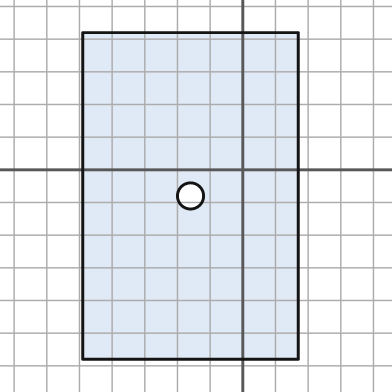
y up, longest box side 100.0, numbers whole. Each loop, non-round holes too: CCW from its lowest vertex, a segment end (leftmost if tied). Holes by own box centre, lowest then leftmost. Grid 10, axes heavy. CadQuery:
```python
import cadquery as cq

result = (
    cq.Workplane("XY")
    .moveTo(-49.0, -58.0)
    .lineTo(17.0, -58.0)
    .lineTo(17.0, 42.0)
    .lineTo(-49.0, 42.0)
    .close()
    .moveTo(-16.0, -8.0)
    .circle(4.0)
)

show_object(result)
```